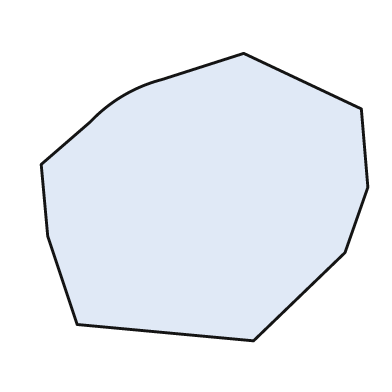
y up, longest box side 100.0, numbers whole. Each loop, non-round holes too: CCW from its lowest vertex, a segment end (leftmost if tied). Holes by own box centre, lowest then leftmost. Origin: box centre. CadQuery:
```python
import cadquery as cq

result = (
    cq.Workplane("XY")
    .moveTo(15.0, -44.0)
    .lineTo(43.0, -17.0)
    .lineTo(50.0, 3.0)
    .lineTo(48.0, 27.0)
    .lineTo(12.0, 44.0)
    .lineTo(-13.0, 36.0)
    .threePointArc((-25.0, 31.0), (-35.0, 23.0))
    .lineTo(-50.0, 10.0)
    .lineTo(-48.0, -12.0)
    .lineTo(-39.0, -39.0)
    .close()
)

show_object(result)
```